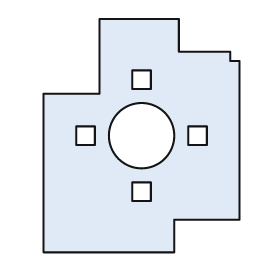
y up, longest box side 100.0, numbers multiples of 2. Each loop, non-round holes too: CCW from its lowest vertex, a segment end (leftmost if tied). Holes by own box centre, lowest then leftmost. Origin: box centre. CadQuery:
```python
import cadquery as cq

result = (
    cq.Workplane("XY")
    .moveTo(-42.0, -50.0)
    .lineTo(14.0, -50.0)
    .lineTo(14.0, -36.0)
    .lineTo(42.0, -36.0)
    .lineTo(42.0, 32.0)
    .lineTo(38.0, 32.0)
    .lineTo(38.0, 36.0)
    .lineTo(16.0, 36.0)
    .lineTo(16.0, 50.0)
    .lineTo(-18.0, 50.0)
    .lineTo(-18.0, 18.0)
    .lineTo(-42.0, 18.0)
    .close()
    .moveTo(-4.0, -28.0)
    .lineTo(4.0, -28.0)
    .lineTo(4.0, -20.0)
    .lineTo(-4.0, -20.0)
    .close()
    .moveTo(-28.0, -4.0)
    .lineTo(-20.0, -4.0)
    .lineTo(-20.0, 4.0)
    .lineTo(-28.0, 4.0)
    .close()
    .moveTo(0.0, 0.0)
    .circle(14.0)
    .moveTo(20.0, -4.0)
    .lineTo(28.0, -4.0)
    .lineTo(28.0, 4.0)
    .lineTo(20.0, 4.0)
    .close()
    .moveTo(-4.0, 20.0)
    .lineTo(4.0, 20.0)
    .lineTo(4.0, 28.0)
    .lineTo(-4.0, 28.0)
    .close()
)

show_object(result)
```